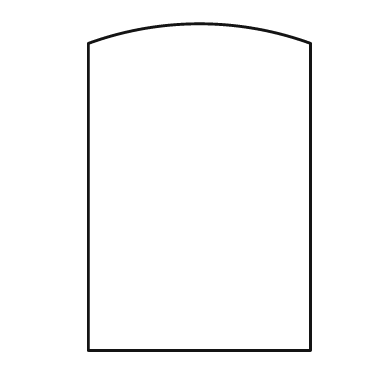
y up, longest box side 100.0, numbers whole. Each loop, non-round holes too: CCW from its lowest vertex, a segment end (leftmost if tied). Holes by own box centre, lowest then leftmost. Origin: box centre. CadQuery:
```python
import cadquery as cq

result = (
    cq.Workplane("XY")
    .moveTo(-34.0, -50.0)
    .lineTo(34.0, -50.0)
    .lineTo(34.0, 44.0)
    .threePointArc((0.0, 50.0), (-34.0, 44.0))
    .close()
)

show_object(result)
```